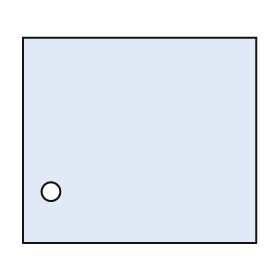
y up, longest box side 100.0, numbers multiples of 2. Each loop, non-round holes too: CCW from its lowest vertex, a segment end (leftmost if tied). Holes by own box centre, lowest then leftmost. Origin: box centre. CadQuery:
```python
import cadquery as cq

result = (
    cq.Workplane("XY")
    .moveTo(-50.0, -44.0)
    .lineTo(50.0, -44.0)
    .lineTo(50.0, 44.0)
    .lineTo(-50.0, 44.0)
    .close()
    .moveTo(-38.0, -22.0)
    .circle(4.0)
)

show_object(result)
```